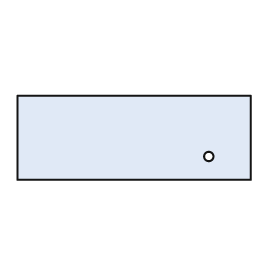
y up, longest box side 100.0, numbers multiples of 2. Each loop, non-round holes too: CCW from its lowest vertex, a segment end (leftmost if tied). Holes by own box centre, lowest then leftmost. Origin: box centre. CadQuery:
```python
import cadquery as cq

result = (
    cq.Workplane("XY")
    .moveTo(-50.0, -18.0)
    .lineTo(50.0, -18.0)
    .lineTo(50.0, 18.0)
    .lineTo(-50.0, 18.0)
    .close()
    .moveTo(32.0, -8.0)
    .circle(2.0)
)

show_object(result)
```